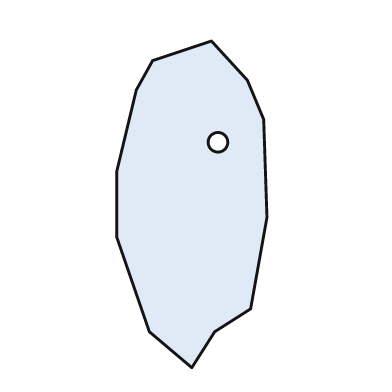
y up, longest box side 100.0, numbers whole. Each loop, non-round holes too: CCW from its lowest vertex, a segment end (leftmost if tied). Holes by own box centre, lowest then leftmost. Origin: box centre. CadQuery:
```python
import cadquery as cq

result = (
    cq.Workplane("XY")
    .moveTo(0.0, -50.0)
    .lineTo(7.0, -39.0)
    .lineTo(18.0, -32.0)
    .lineTo(23.0, -4.0)
    .lineTo(22.0, 26.0)
    .lineTo(17.0, 38.0)
    .lineTo(6.0, 50.0)
    .lineTo(-12.0, 44.0)
    .lineTo(-17.0, 35.0)
    .lineTo(-23.0, 10.0)
    .lineTo(-23.0, -10.0)
    .lineTo(-13.0, -39.0)
    .close()
    .moveTo(8.0, 19.0)
    .circle(3.0)
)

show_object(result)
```